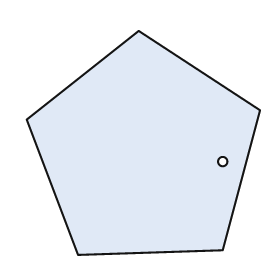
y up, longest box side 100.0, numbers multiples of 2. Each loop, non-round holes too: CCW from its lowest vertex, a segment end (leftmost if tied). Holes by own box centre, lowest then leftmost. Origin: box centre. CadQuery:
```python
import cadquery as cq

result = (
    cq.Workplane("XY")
    .moveTo(-28.0, -48.0)
    .lineTo(34.0, -46.0)
    .lineTo(50.0, 14.0)
    .lineTo(-2.0, 48.0)
    .lineTo(-50.0, 10.0)
    .close()
    .moveTo(34.0, -8.0)
    .circle(2.0)
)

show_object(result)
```